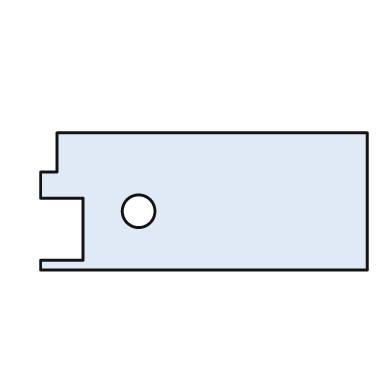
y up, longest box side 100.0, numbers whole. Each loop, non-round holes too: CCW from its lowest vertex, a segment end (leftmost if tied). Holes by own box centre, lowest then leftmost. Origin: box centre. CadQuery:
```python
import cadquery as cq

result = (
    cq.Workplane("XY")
    .moveTo(-50.0, -21.0)
    .lineTo(50.0, -21.0)
    .lineTo(50.0, 21.0)
    .lineTo(-45.0, 21.0)
    .lineTo(-45.0, 9.0)
    .lineTo(-50.0, 9.0)
    .lineTo(-50.0, 1.0)
    .lineTo(-37.0, 1.0)
    .lineTo(-37.0, -18.0)
    .lineTo(-50.0, -18.0)
    .close()
    .moveTo(-20.0, -3.0)
    .circle(5.0)
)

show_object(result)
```